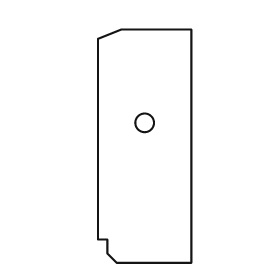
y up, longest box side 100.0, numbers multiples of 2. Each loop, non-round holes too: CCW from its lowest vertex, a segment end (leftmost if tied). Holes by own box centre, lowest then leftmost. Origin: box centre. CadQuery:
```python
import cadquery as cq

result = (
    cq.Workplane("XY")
    .moveTo(-12.0, -50.0)
    .lineTo(20.0, -50.0)
    .lineTo(20.0, 50.0)
    .lineTo(-10.0, 50.0)
    .lineTo(-20.0, 46.0)
    .lineTo(-20.0, -40.0)
    .lineTo(-16.0, -40.0)
    .lineTo(-16.0, -46.0)
    .close()
    .moveTo(0.0, 10.0)
    .circle(4.0)
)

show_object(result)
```